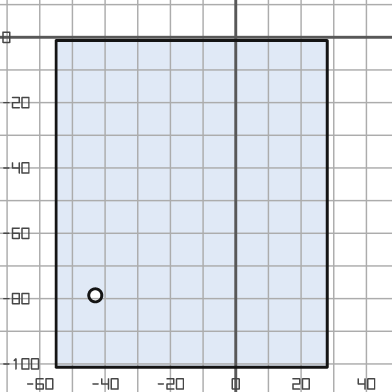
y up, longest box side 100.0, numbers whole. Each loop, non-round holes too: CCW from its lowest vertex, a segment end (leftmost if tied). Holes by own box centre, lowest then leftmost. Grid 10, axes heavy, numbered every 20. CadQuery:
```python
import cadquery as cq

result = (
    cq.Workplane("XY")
    .moveTo(-55.0, -101.0)
    .lineTo(28.0, -101.0)
    .lineTo(28.0, -1.0)
    .lineTo(-55.0, -1.0)
    .close()
    .moveTo(-43.0, -79.0)
    .circle(2.0)
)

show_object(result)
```